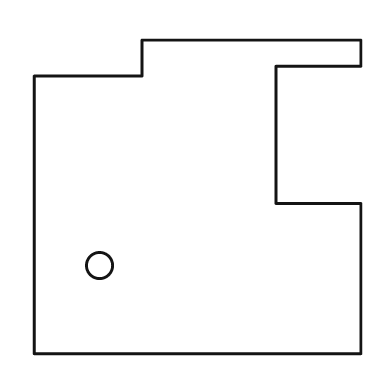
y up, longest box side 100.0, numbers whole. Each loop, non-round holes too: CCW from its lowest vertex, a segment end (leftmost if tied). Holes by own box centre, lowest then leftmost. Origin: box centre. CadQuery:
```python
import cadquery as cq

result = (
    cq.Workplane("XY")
    .moveTo(-50.0, -48.0)
    .lineTo(50.0, -48.0)
    .lineTo(50.0, -2.0)
    .lineTo(24.0, -2.0)
    .lineTo(24.0, 40.0)
    .lineTo(50.0, 40.0)
    .lineTo(50.0, 48.0)
    .lineTo(-17.0, 48.0)
    .lineTo(-17.0, 37.0)
    .lineTo(-50.0, 37.0)
    .close()
    .moveTo(-30.0, -21.0)
    .circle(4.0)
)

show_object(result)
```